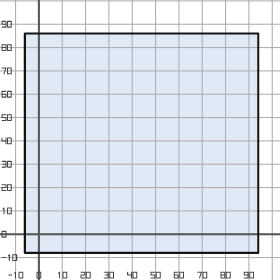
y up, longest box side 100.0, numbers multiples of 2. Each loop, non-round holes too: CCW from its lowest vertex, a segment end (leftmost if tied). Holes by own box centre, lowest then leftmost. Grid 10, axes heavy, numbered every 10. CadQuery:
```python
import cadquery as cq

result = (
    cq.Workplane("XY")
    .moveTo(-6.0, -8.0)
    .lineTo(94.0, -8.0)
    .lineTo(94.0, 86.0)
    .lineTo(-6.0, 86.0)
    .close()
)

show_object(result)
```